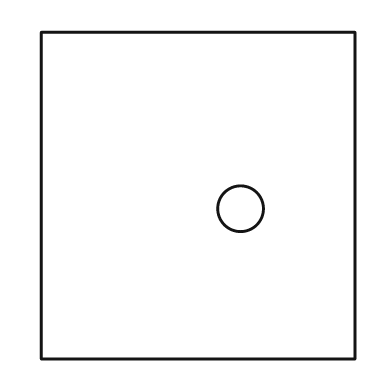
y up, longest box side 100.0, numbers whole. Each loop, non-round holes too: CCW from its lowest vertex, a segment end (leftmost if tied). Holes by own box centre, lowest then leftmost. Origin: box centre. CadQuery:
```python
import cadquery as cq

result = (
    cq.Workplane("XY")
    .moveTo(-48.0, -50.0)
    .lineTo(48.0, -50.0)
    .lineTo(48.0, 50.0)
    .lineTo(-48.0, 50.0)
    .close()
    .moveTo(13.0, -4.0)
    .circle(7.0)
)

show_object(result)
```